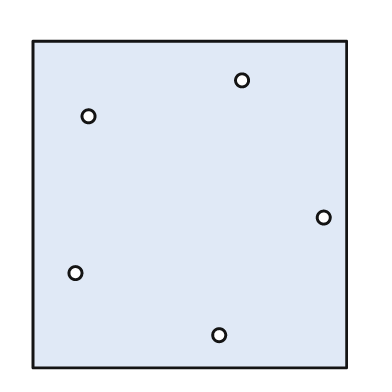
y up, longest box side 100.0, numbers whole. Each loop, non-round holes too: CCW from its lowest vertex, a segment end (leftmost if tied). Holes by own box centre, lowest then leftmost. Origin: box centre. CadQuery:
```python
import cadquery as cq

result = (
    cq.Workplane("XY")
    .moveTo(-48.0, -50.0)
    .lineTo(48.0, -50.0)
    .lineTo(48.0, 50.0)
    .lineTo(-48.0, 50.0)
    .close()
    .moveTo(9.0, -40.0)
    .circle(2.0)
    .moveTo(-35.0, -21.0)
    .circle(2.0)
    .moveTo(41.0, -4.0)
    .circle(2.0)
    .moveTo(-31.0, 27.0)
    .circle(2.0)
    .moveTo(16.0, 38.0)
    .circle(2.0)
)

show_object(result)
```